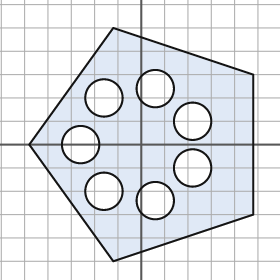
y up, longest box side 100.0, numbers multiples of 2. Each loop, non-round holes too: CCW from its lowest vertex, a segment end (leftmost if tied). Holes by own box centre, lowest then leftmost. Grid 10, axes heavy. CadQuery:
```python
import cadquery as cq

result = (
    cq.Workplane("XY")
    .moveTo(-12.0, -50.0)
    .lineTo(48.0, -30.0)
    .lineTo(48.0, 30.0)
    .lineTo(-12.0, 50.0)
    .lineTo(-48.0, 0.0)
    .close()
    .moveTo(6.0, -24.0)
    .circle(8.0)
    .moveTo(-16.0, -20.0)
    .circle(8.0)
    .moveTo(22.0, -10.0)
    .circle(8.0)
    .moveTo(-26.0, 0.0)
    .circle(8.0)
    .moveTo(22.0, 10.0)
    .circle(8.0)
    .moveTo(-16.0, 20.0)
    .circle(8.0)
    .moveTo(6.0, 24.0)
    .circle(8.0)
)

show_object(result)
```